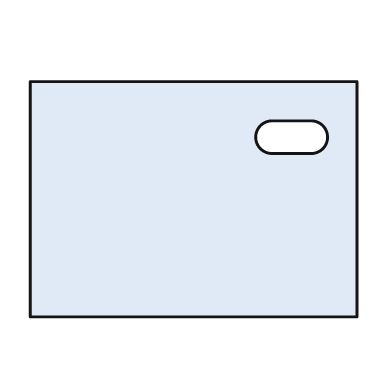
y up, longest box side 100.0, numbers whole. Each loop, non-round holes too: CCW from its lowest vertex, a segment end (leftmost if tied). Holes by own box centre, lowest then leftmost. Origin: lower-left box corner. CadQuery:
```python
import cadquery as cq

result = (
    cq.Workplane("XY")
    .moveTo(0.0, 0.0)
    .lineTo(100.0, 0.0)
    .lineTo(100.0, 72.0)
    .lineTo(0.0, 72.0)
    .close()
    .moveTo(74.0, 50.0)
    .lineTo(86.0, 50.0)
    .threePointArc((91.0, 55.0), (86.0, 60.0))
    .lineTo(74.0, 60.0)
    .threePointArc((69.0, 55.0), (74.0, 50.0))
    .close()
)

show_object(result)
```